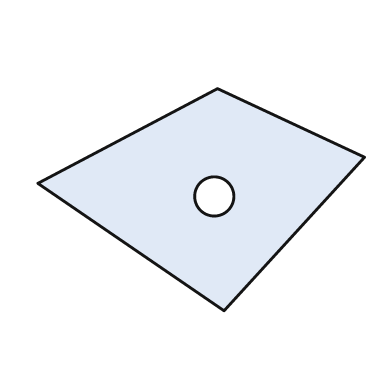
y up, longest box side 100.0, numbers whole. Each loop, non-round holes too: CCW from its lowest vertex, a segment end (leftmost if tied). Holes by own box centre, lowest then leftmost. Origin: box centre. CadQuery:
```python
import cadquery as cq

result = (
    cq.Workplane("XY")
    .moveTo(7.0, -34.0)
    .lineTo(50.0, 13.0)
    .lineTo(5.0, 34.0)
    .lineTo(-50.0, 5.0)
    .close()
    .moveTo(4.0, 1.0)
    .circle(6.0)
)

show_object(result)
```